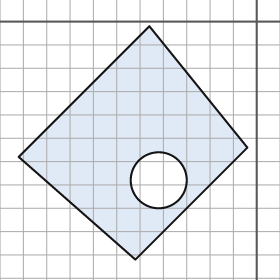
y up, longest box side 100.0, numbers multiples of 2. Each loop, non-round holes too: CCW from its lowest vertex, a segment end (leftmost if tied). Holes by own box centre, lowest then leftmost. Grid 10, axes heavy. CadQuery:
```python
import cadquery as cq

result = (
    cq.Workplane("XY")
    .moveTo(-52.0, -102.0)
    .lineTo(-4.0, -54.0)
    .lineTo(-46.0, -2.0)
    .lineTo(-102.0, -58.0)
    .close()
    .moveTo(-42.0, -68.0)
    .circle(12.0)
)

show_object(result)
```